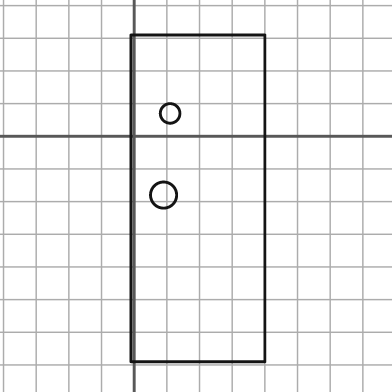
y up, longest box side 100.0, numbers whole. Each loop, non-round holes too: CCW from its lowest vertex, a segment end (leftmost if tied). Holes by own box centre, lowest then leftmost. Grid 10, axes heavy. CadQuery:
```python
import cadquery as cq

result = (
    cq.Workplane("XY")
    .moveTo(-1.0, -69.0)
    .lineTo(40.0, -69.0)
    .lineTo(40.0, 31.0)
    .lineTo(-1.0, 31.0)
    .close()
    .moveTo(9.0, -18.0)
    .circle(4.0)
    .moveTo(11.0, 7.0)
    .circle(3.0)
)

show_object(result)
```